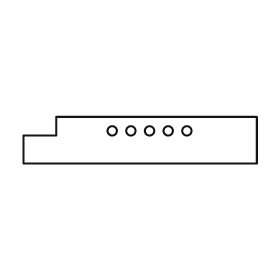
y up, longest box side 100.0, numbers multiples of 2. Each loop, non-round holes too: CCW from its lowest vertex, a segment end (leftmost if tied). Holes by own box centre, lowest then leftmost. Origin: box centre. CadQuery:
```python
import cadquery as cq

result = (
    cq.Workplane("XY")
    .moveTo(-50.0, -10.0)
    .lineTo(50.0, -10.0)
    .lineTo(50.0, 10.0)
    .lineTo(-36.0, 10.0)
    .lineTo(-36.0, 2.0)
    .lineTo(-50.0, 2.0)
    .close()
    .moveTo(-12.0, 4.0)
    .circle(2.0)
    .moveTo(-4.0, 4.0)
    .circle(2.0)
    .moveTo(4.0, 4.0)
    .circle(2.0)
    .moveTo(12.0, 4.0)
    .circle(2.0)
    .moveTo(20.0, 4.0)
    .circle(2.0)
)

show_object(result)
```